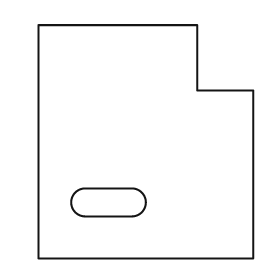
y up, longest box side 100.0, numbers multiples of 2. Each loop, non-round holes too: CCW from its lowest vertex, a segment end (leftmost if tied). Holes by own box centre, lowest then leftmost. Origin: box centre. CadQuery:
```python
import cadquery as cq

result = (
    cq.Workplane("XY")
    .moveTo(-46.0, -50.0)
    .lineTo(46.0, -50.0)
    .lineTo(46.0, 22.0)
    .lineTo(22.0, 22.0)
    .lineTo(22.0, 50.0)
    .lineTo(-46.0, 50.0)
    .close()
    .moveTo(-26.0, -32.0)
    .lineTo(-6.0, -32.0)
    .threePointArc((0.0, -26.0), (-6.0, -20.0))
    .lineTo(-26.0, -20.0)
    .threePointArc((-32.0, -26.0), (-26.0, -32.0))
    .close()
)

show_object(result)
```